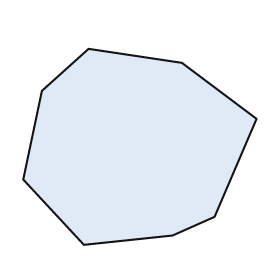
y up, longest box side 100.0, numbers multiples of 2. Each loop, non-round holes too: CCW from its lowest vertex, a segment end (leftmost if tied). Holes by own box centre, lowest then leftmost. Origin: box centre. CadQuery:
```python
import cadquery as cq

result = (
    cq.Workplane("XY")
    .moveTo(-24.0, -42.0)
    .lineTo(14.0, -38.0)
    .lineTo(32.0, -30.0)
    .lineTo(50.0, 12.0)
    .lineTo(18.0, 36.0)
    .lineTo(-22.0, 42.0)
    .lineTo(-42.0, 24.0)
    .lineTo(-50.0, -14.0)
    .close()
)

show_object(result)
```